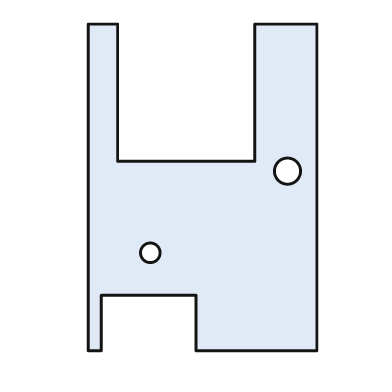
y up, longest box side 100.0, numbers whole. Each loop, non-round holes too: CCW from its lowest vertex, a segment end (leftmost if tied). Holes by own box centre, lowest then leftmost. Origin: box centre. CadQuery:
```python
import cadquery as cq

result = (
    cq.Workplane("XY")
    .moveTo(-35.0, -50.0)
    .lineTo(-31.0, -50.0)
    .lineTo(-31.0, -33.0)
    .lineTo(-2.0, -33.0)
    .lineTo(-2.0, -50.0)
    .lineTo(35.0, -50.0)
    .lineTo(35.0, 50.0)
    .lineTo(16.0, 50.0)
    .lineTo(16.0, 8.0)
    .lineTo(-26.0, 8.0)
    .lineTo(-26.0, 50.0)
    .lineTo(-35.0, 50.0)
    .close()
    .moveTo(-16.0, -20.0)
    .circle(3.0)
    .moveTo(26.0, 5.0)
    .circle(4.0)
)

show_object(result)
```